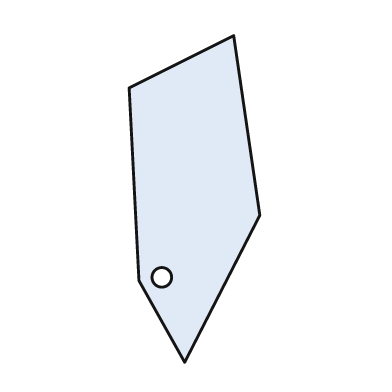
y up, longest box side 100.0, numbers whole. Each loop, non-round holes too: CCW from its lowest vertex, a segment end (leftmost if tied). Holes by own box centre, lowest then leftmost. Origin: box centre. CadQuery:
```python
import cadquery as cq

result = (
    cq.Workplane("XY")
    .moveTo(-3.0, -50.0)
    .lineTo(20.0, -5.0)
    .lineTo(12.0, 50.0)
    .lineTo(-20.0, 34.0)
    .lineTo(-17.0, -25.0)
    .close()
    .moveTo(-10.0, -24.0)
    .circle(3.0)
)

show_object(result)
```